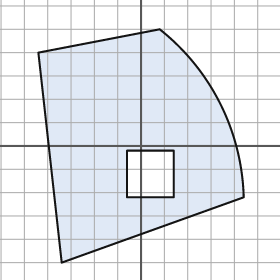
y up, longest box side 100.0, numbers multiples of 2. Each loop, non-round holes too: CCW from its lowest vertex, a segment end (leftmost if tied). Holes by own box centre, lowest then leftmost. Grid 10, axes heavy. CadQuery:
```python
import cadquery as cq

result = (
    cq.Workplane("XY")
    .moveTo(-34.0, -50.0)
    .lineTo(44.0, -22.0)
    .threePointArc((34.0, 18.0), (8.0, 50.0))
    .lineTo(-44.0, 40.0)
    .close()
    .moveTo(-6.0, -22.0)
    .lineTo(14.0, -22.0)
    .lineTo(14.0, -2.0)
    .lineTo(-6.0, -2.0)
    .close()
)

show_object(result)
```